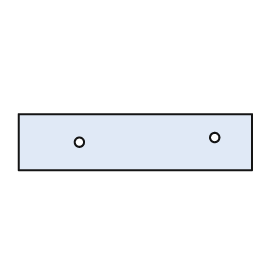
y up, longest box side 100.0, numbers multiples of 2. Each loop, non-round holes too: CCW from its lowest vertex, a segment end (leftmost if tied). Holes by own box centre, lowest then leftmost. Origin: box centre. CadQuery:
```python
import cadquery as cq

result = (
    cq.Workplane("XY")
    .moveTo(-50.0, -12.0)
    .lineTo(50.0, -12.0)
    .lineTo(50.0, 12.0)
    .lineTo(-50.0, 12.0)
    .close()
    .moveTo(-24.0, 0.0)
    .circle(2.0)
    .moveTo(34.0, 2.0)
    .circle(2.0)
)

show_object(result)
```